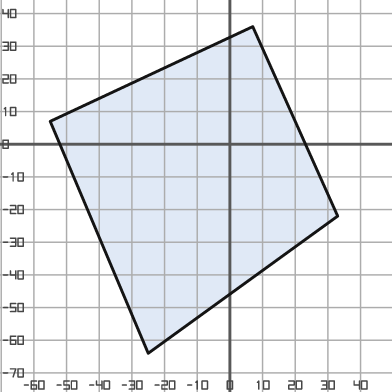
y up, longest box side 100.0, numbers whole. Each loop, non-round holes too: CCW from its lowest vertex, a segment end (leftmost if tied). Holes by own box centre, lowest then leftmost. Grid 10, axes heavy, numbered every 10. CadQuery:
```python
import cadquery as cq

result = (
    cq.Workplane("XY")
    .moveTo(-25.0, -64.0)
    .lineTo(33.0, -22.0)
    .lineTo(7.0, 36.0)
    .lineTo(-55.0, 7.0)
    .close()
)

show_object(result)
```